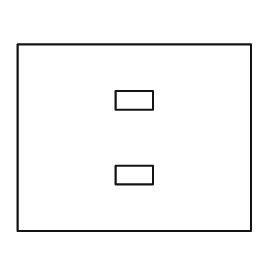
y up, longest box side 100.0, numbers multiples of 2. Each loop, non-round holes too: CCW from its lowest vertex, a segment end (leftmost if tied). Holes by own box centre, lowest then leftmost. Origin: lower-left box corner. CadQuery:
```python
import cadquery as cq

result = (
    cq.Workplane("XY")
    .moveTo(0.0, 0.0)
    .lineTo(100.0, 0.0)
    .lineTo(100.0, 80.0)
    .lineTo(0.0, 80.0)
    .close()
    .moveTo(42.0, 20.0)
    .lineTo(58.0, 20.0)
    .lineTo(58.0, 28.0)
    .lineTo(42.0, 28.0)
    .close()
    .moveTo(42.0, 52.0)
    .lineTo(58.0, 52.0)
    .lineTo(58.0, 60.0)
    .lineTo(42.0, 60.0)
    .close()
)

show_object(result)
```